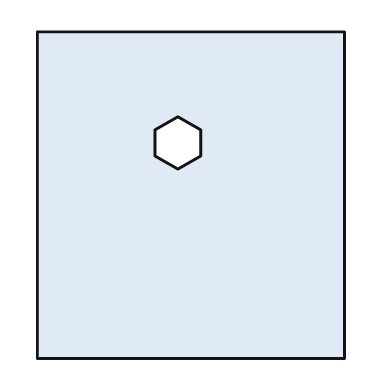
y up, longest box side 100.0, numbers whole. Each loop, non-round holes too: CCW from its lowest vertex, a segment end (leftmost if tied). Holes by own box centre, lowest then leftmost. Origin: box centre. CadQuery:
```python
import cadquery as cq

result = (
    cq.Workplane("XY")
    .moveTo(-47.0, -50.0)
    .lineTo(47.0, -50.0)
    .lineTo(47.0, 50.0)
    .lineTo(-47.0, 50.0)
    .close()
    .moveTo(-4.0, 8.0)
    .lineTo(3.0, 12.0)
    .lineTo(3.0, 20.0)
    .lineTo(-4.0, 24.0)
    .lineTo(-11.0, 20.0)
    .lineTo(-11.0, 12.0)
    .close()
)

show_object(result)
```